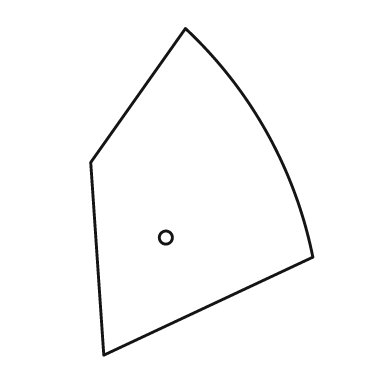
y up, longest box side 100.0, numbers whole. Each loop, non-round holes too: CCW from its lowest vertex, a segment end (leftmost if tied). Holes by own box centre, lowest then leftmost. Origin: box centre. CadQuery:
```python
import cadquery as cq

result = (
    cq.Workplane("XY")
    .moveTo(-30.0, -50.0)
    .lineTo(34.0, -20.0)
    .threePointArc((20.0, 18.0), (-5.0, 50.0))
    .lineTo(-34.0, 9.0)
    .close()
    .moveTo(-11.0, -14.0)
    .circle(2.0)
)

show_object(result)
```